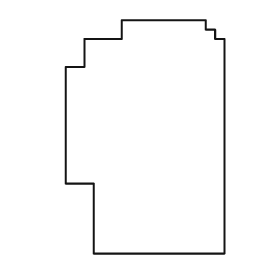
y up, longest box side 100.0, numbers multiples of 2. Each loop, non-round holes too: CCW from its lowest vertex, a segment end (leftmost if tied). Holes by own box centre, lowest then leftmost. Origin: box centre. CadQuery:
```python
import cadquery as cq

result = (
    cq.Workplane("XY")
    .moveTo(-22.0, -50.0)
    .lineTo(34.0, -50.0)
    .lineTo(34.0, 42.0)
    .lineTo(30.0, 42.0)
    .lineTo(30.0, 46.0)
    .lineTo(26.0, 46.0)
    .lineTo(26.0, 50.0)
    .lineTo(-10.0, 50.0)
    .lineTo(-10.0, 42.0)
    .lineTo(-26.0, 42.0)
    .lineTo(-26.0, 30.0)
    .lineTo(-34.0, 30.0)
    .lineTo(-34.0, -20.0)
    .lineTo(-22.0, -20.0)
    .close()
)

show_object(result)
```